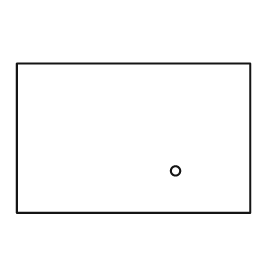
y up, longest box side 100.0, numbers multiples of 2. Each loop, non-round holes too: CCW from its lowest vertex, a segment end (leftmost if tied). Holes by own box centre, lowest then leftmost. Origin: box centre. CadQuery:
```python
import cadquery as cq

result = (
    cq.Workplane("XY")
    .moveTo(-50.0, -32.0)
    .lineTo(50.0, -32.0)
    .lineTo(50.0, 32.0)
    .lineTo(-50.0, 32.0)
    .close()
    .moveTo(18.0, -14.0)
    .circle(2.0)
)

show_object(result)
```